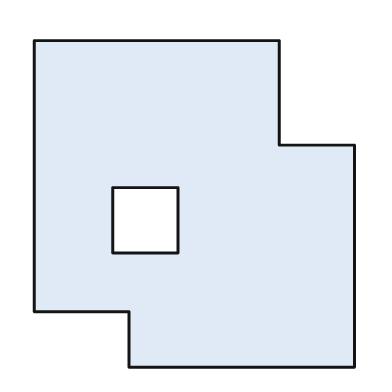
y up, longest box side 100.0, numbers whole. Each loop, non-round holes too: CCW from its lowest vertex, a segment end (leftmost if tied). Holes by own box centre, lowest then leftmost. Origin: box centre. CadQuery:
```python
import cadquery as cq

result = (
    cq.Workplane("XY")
    .moveTo(-20.0, -50.0)
    .lineTo(49.0, -50.0)
    .lineTo(49.0, 18.0)
    .lineTo(26.0, 18.0)
    .lineTo(26.0, 50.0)
    .lineTo(-49.0, 50.0)
    .lineTo(-49.0, -33.0)
    .lineTo(-20.0, -33.0)
    .close()
    .moveTo(-25.0, -15.0)
    .lineTo(-5.0, -15.0)
    .lineTo(-5.0, 5.0)
    .lineTo(-25.0, 5.0)
    .close()
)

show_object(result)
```